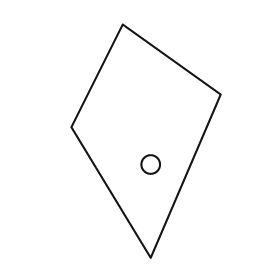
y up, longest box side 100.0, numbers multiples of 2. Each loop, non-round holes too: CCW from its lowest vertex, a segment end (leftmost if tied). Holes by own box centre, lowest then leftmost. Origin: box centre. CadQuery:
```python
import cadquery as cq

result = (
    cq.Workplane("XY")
    .moveTo(2.0, -50.0)
    .lineTo(32.0, 20.0)
    .lineTo(-10.0, 50.0)
    .lineTo(-32.0, 6.0)
    .close()
    .moveTo(2.0, -10.0)
    .circle(4.0)
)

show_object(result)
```